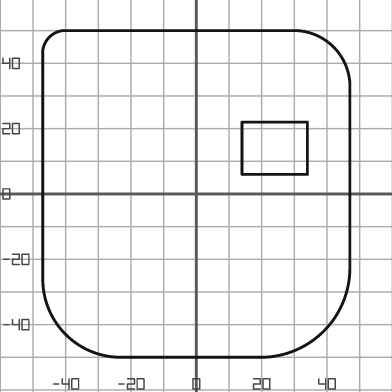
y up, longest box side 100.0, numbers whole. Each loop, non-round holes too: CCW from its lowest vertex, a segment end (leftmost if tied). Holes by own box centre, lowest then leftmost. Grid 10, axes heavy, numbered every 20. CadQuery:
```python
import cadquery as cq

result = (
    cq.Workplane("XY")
    .moveTo(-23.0, -50.0)
    .lineTo(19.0, -50.0)
    .threePointArc((39.0, -42.0), (47.0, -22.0))
    .lineTo(47.0, 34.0)
    .threePointArc((42.0, 45.0), (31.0, 50.0))
    .lineTo(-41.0, 50.0)
    .threePointArc((-45.0, 48.0), (-47.0, 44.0))
    .lineTo(-47.0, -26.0)
    .threePointArc((-40.0, -43.0), (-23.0, -50.0))
    .close()
    .moveTo(14.0, 6.0)
    .lineTo(34.0, 6.0)
    .lineTo(34.0, 22.0)
    .lineTo(14.0, 22.0)
    .close()
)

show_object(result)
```